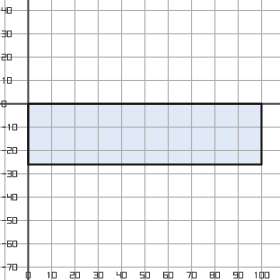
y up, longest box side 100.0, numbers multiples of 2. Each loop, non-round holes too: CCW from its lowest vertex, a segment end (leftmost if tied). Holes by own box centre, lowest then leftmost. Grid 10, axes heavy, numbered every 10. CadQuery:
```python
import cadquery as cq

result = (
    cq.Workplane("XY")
    .moveTo(0.0, -26.0)
    .lineTo(100.0, -26.0)
    .lineTo(100.0, 0.0)
    .lineTo(0.0, 0.0)
    .close()
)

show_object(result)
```